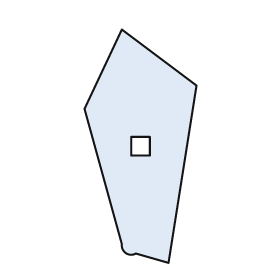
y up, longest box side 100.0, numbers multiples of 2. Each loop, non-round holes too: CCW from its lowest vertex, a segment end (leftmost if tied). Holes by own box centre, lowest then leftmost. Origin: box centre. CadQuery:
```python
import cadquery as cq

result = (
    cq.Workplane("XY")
    .moveTo(12.0, -50.0)
    .lineTo(24.0, 26.0)
    .lineTo(-8.0, 50.0)
    .lineTo(-24.0, 16.0)
    .lineTo(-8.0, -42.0)
    .threePointArc((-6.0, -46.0), (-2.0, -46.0))
    .close()
    .moveTo(-4.0, -4.0)
    .lineTo(4.0, -4.0)
    .lineTo(4.0, 4.0)
    .lineTo(-4.0, 4.0)
    .close()
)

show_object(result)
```